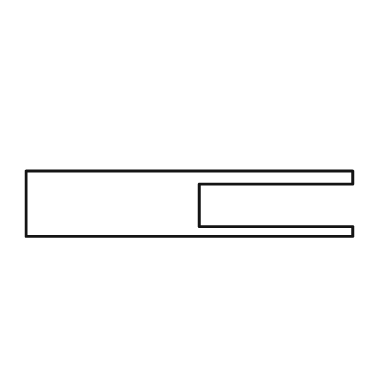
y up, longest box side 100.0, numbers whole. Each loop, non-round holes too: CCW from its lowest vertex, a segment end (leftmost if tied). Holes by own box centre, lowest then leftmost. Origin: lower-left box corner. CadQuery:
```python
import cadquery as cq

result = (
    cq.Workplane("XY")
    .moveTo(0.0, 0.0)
    .lineTo(100.0, 0.0)
    .lineTo(100.0, 3.0)
    .lineTo(53.0, 3.0)
    .lineTo(53.0, 16.0)
    .lineTo(100.0, 16.0)
    .lineTo(100.0, 20.0)
    .lineTo(0.0, 20.0)
    .close()
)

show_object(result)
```